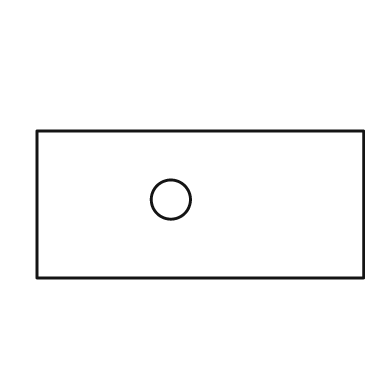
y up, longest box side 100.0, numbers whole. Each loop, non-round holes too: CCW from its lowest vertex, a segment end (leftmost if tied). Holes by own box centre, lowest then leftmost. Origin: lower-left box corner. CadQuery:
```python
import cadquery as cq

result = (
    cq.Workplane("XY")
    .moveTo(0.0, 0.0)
    .lineTo(100.0, 0.0)
    .lineTo(100.0, 45.0)
    .lineTo(0.0, 45.0)
    .close()
    .moveTo(41.0, 24.0)
    .circle(6.0)
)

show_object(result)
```